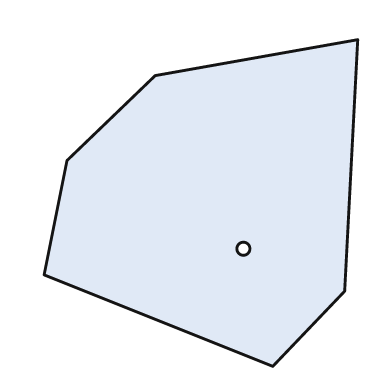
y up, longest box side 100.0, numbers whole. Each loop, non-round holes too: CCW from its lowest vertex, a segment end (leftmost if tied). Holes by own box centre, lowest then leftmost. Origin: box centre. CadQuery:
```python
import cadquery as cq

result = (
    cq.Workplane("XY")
    .moveTo(22.0, -50.0)
    .lineTo(44.0, -27.0)
    .lineTo(48.0, 50.0)
    .lineTo(-14.0, 39.0)
    .lineTo(-41.0, 13.0)
    .lineTo(-48.0, -22.0)
    .close()
    .moveTo(13.0, -14.0)
    .circle(2.0)
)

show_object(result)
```